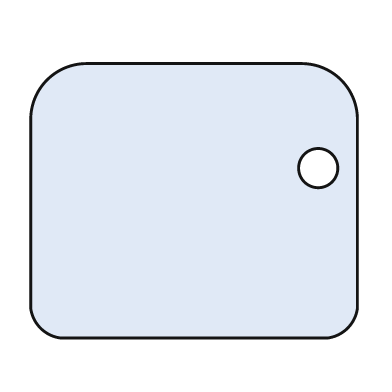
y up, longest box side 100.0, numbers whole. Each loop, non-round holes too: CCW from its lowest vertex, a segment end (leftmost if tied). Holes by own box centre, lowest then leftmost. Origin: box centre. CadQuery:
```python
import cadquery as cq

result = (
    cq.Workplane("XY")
    .moveTo(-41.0, -42.0)
    .lineTo(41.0, -42.0)
    .threePointArc((47.0, -39.0), (50.0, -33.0))
    .lineTo(50.0, 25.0)
    .threePointArc((45.0, 37.0), (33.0, 42.0))
    .lineTo(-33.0, 42.0)
    .threePointArc((-45.0, 37.0), (-50.0, 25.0))
    .lineTo(-50.0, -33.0)
    .threePointArc((-47.0, -39.0), (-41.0, -42.0))
    .close()
    .moveTo(38.0, 10.0)
    .circle(6.0)
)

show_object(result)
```